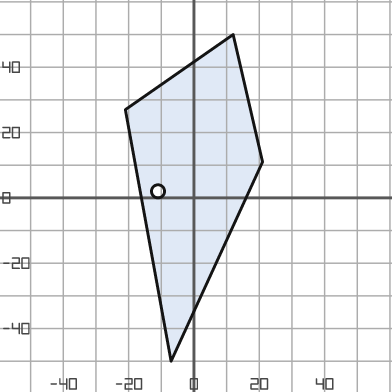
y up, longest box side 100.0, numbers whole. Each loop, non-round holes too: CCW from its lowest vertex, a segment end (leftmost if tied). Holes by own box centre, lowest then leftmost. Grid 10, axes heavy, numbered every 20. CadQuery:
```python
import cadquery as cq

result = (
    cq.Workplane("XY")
    .moveTo(-7.0, -50.0)
    .lineTo(21.0, 11.0)
    .lineTo(12.0, 50.0)
    .lineTo(-21.0, 27.0)
    .close()
    .moveTo(-11.0, 2.0)
    .circle(2.0)
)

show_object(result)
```